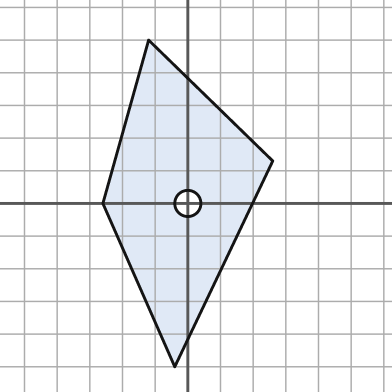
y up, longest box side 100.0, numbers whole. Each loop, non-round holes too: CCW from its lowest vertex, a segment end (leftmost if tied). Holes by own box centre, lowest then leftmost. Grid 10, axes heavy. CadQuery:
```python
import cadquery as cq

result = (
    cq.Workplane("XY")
    .moveTo(-4.0, -50.0)
    .lineTo(26.0, 13.0)
    .lineTo(-12.0, 50.0)
    .lineTo(-26.0, 0.0)
    .close()
    .moveTo(0.0, 0.0)
    .circle(4.0)
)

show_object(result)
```